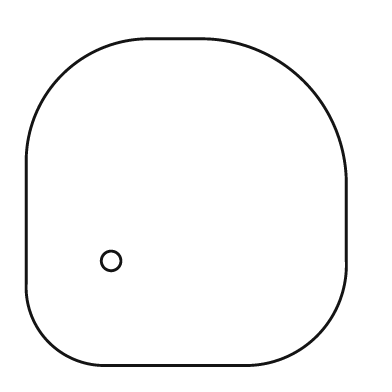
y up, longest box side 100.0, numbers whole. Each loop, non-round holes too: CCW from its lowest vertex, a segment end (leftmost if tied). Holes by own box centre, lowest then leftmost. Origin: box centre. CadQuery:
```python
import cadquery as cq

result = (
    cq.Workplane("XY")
    .moveTo(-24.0, -50.0)
    .lineTo(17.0, -50.0)
    .threePointArc((40.0, -41.0), (49.0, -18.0))
    .lineTo(49.0, 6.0)
    .threePointArc((36.0, 37.0), (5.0, 50.0))
    .lineTo(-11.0, 50.0)
    .threePointArc((-38.0, 39.0), (-49.0, 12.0))
    .lineTo(-49.0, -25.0)
    .threePointArc((-42.0, -43.0), (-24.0, -50.0))
    .close()
    .moveTo(-23.0, -18.0)
    .circle(3.0)
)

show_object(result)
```